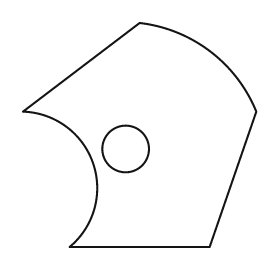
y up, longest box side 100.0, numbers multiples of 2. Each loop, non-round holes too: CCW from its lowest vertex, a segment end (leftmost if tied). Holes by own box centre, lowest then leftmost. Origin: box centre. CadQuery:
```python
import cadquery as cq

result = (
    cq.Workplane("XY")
    .moveTo(-30.0, -48.0)
    .lineTo(30.0, -48.0)
    .lineTo(50.0, 10.0)
    .threePointArc((30.0, 36.0), (0.0, 48.0))
    .lineTo(-50.0, 10.0)
    .threePointArc((-20.0, -12.0), (-30.0, -48.0))
    .close()
    .moveTo(-6.0, -6.0)
    .circle(10.0)
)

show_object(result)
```